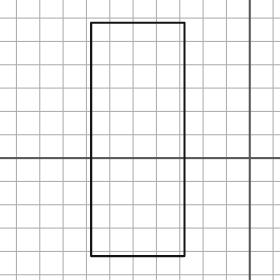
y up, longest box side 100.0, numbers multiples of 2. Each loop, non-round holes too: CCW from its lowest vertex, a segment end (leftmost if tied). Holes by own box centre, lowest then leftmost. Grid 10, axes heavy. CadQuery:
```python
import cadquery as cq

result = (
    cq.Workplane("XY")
    .moveTo(-68.0, -42.0)
    .lineTo(-28.0, -42.0)
    .lineTo(-28.0, 58.0)
    .lineTo(-68.0, 58.0)
    .close()
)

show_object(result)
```